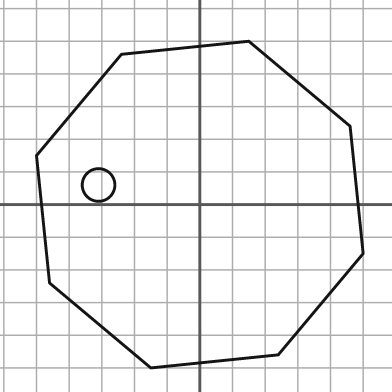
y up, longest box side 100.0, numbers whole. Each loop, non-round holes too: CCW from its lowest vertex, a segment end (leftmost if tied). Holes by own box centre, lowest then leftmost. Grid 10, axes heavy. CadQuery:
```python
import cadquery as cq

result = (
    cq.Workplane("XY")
    .moveTo(-15.0, -50.0)
    .lineTo(24.0, -46.0)
    .lineTo(50.0, -15.0)
    .lineTo(46.0, 24.0)
    .lineTo(15.0, 50.0)
    .lineTo(-24.0, 46.0)
    .lineTo(-50.0, 15.0)
    .lineTo(-46.0, -24.0)
    .close()
    .moveTo(-31.0, 6.0)
    .circle(5.0)
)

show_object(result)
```